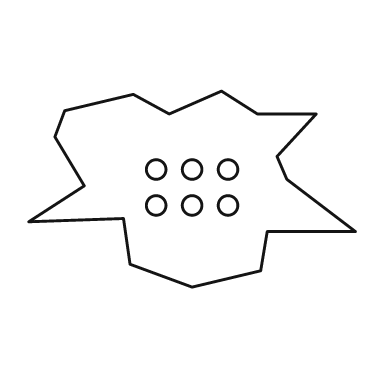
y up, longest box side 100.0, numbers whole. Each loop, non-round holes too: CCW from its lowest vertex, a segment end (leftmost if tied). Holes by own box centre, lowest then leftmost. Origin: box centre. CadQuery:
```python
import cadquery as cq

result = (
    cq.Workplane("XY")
    .moveTo(0.0, -30.0)
    .lineTo(21.0, -25.0)
    .lineTo(23.0, -13.0)
    .lineTo(50.0, -13.0)
    .lineTo(29.0, 3.0)
    .lineTo(26.0, 10.0)
    .lineTo(38.0, 23.0)
    .lineTo(20.0, 23.0)
    .lineTo(9.0, 30.0)
    .lineTo(-7.0, 23.0)
    .lineTo(-18.0, 29.0)
    .lineTo(-39.0, 24.0)
    .lineTo(-42.0, 16.0)
    .lineTo(-33.0, 1.0)
    .lineTo(-50.0, -10.0)
    .lineTo(-21.0, -9.0)
    .lineTo(-19.0, -23.0)
    .close()
    .moveTo(-11.0, -5.0)
    .circle(3.0)
    .moveTo(0.0, -5.0)
    .circle(3.0)
    .moveTo(11.0, -5.0)
    .circle(3.0)
    .moveTo(-11.0, 6.0)
    .circle(3.0)
    .moveTo(0.0, 6.0)
    .circle(3.0)
    .moveTo(11.0, 6.0)
    .circle(3.0)
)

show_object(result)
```